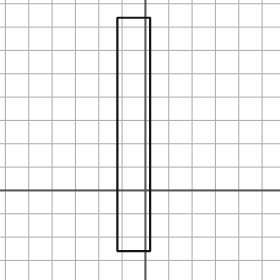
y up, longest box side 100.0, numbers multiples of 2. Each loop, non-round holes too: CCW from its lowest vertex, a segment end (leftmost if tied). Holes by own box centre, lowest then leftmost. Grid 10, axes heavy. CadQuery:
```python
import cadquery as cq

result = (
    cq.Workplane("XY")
    .moveTo(-12.0, -26.0)
    .lineTo(2.0, -26.0)
    .lineTo(2.0, 74.0)
    .lineTo(-12.0, 74.0)
    .close()
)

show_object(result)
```